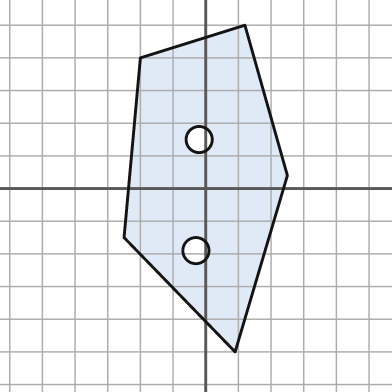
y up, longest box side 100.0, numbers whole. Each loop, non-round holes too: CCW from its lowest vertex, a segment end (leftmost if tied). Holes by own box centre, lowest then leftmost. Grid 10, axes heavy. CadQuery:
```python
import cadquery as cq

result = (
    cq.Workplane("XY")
    .moveTo(9.0, -50.0)
    .lineTo(25.0, 4.0)
    .lineTo(12.0, 50.0)
    .lineTo(-20.0, 40.0)
    .lineTo(-25.0, -15.0)
    .close()
    .moveTo(-3.0, -19.0)
    .circle(4.0)
    .moveTo(-2.0, 15.0)
    .circle(4.0)
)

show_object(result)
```